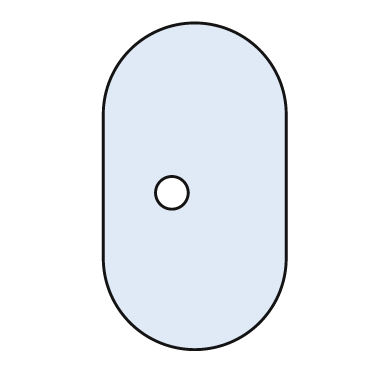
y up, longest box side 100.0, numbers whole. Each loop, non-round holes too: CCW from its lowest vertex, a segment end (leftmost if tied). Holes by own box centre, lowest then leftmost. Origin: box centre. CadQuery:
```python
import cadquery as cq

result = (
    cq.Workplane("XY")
    .moveTo(-28.0, -22.0)
    .threePointArc((0.0, -50.0), (28.0, -22.0))
    .lineTo(28.0, 22.0)
    .threePointArc((0.0, 50.0), (-28.0, 22.0))
    .close()
    .moveTo(-7.0, -2.0)
    .circle(5.0)
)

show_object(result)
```